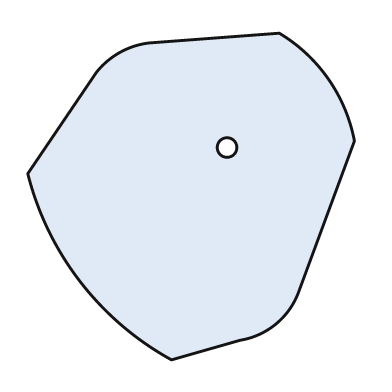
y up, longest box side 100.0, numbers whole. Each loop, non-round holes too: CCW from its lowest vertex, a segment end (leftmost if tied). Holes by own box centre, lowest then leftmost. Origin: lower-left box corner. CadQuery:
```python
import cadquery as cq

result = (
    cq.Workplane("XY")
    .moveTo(44.0, 0.0)
    .lineTo(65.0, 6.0)
    .threePointArc((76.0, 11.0), (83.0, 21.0))
    .lineTo(100.0, 67.0)
    .threePointArc((92.0, 86.0), (77.0, 100.0))
    .lineTo(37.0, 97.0)
    .threePointArc((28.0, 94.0), (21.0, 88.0))
    .lineTo(0.0, 57.0)
    .threePointArc((16.0, 24.0), (44.0, 0.0))
    .close()
    .moveTo(61.0, 65.0)
    .circle(3.0)
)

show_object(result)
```